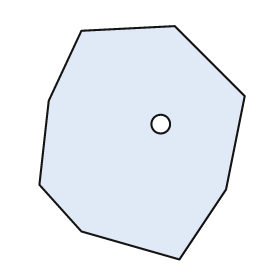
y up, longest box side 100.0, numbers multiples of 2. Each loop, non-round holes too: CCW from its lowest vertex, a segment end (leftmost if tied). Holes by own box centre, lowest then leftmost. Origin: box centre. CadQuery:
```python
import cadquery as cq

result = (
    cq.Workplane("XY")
    .moveTo(16.0, -50.0)
    .lineTo(36.0, -20.0)
    .lineTo(44.0, 20.0)
    .lineTo(14.0, 50.0)
    .lineTo(-26.0, 48.0)
    .lineTo(-40.0, 18.0)
    .lineTo(-44.0, -18.0)
    .lineTo(-26.0, -38.0)
    .close()
    .moveTo(8.0, 8.0)
    .circle(4.0)
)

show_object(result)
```